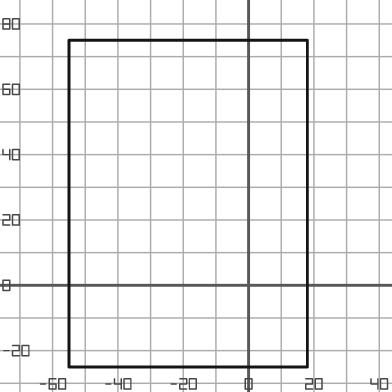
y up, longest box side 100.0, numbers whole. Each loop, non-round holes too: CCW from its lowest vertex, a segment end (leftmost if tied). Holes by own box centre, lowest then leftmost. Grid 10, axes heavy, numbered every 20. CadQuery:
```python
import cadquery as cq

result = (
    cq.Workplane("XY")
    .moveTo(-55.0, -25.0)
    .lineTo(18.0, -25.0)
    .lineTo(18.0, 75.0)
    .lineTo(-55.0, 75.0)
    .close()
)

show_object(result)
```